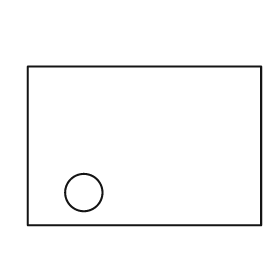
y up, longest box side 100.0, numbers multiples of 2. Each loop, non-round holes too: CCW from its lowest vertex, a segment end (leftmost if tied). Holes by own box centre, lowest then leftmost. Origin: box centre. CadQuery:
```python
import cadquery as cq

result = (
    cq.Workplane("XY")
    .moveTo(-50.0, -34.0)
    .lineTo(50.0, -34.0)
    .lineTo(50.0, 34.0)
    .lineTo(-50.0, 34.0)
    .close()
    .moveTo(-26.0, -20.0)
    .circle(8.0)
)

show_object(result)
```